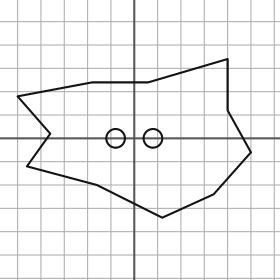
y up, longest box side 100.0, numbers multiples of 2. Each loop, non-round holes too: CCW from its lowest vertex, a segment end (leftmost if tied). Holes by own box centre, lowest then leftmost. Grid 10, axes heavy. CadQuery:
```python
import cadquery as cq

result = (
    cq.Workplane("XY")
    .moveTo(12.0, -34.0)
    .lineTo(34.0, -24.0)
    .lineTo(50.0, -6.0)
    .lineTo(40.0, 12.0)
    .lineTo(40.0, 34.0)
    .lineTo(6.0, 24.0)
    .lineTo(-18.0, 24.0)
    .lineTo(-50.0, 18.0)
    .lineTo(-36.0, 2.0)
    .lineTo(-46.0, -12.0)
    .lineTo(-16.0, -20.0)
    .close()
    .moveTo(-8.0, 0.0)
    .circle(4.0)
    .moveTo(8.0, 0.0)
    .circle(4.0)
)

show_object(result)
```